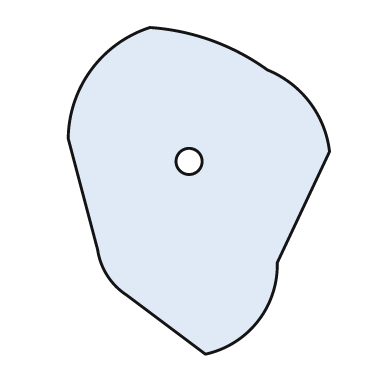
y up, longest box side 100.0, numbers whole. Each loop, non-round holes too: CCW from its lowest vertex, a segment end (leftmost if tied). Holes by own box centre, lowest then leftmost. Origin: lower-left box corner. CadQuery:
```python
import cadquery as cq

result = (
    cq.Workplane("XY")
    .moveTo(42.0, 0.0)
    .threePointArc((58.0, 10.0), (64.0, 28.0))
    .lineTo(80.0, 62.0)
    .threePointArc((74.0, 77.0), (61.0, 87.0))
    .threePointArc((44.0, 96.0), (25.0, 100.0))
    .threePointArc((7.0, 87.0), (0.0, 66.0))
    .lineTo(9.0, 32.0)
    .threePointArc((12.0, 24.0), (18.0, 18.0))
    .close()
    .moveTo(37.0, 59.0)
    .circle(4.0)
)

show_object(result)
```